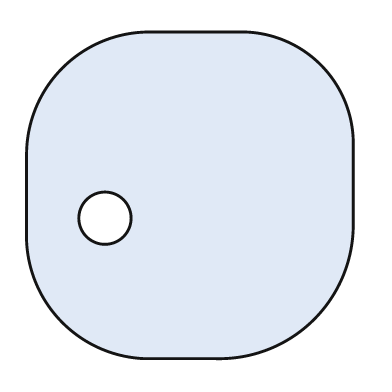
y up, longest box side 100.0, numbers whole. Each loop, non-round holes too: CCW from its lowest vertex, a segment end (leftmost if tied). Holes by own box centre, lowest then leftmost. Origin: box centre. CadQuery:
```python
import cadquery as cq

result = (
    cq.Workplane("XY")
    .moveTo(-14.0, -50.0)
    .lineTo(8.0, -50.0)
    .threePointArc((38.0, -38.0), (50.0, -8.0))
    .lineTo(50.0, 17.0)
    .threePointArc((40.0, 40.0), (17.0, 50.0))
    .lineTo(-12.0, 50.0)
    .threePointArc((-39.0, 39.0), (-50.0, 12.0))
    .lineTo(-50.0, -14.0)
    .threePointArc((-39.0, -39.0), (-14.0, -50.0))
    .close()
    .moveTo(-26.0, -7.0)
    .circle(8.0)
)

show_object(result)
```